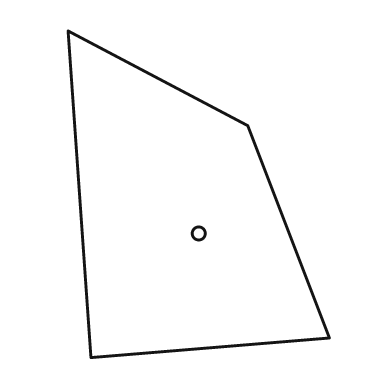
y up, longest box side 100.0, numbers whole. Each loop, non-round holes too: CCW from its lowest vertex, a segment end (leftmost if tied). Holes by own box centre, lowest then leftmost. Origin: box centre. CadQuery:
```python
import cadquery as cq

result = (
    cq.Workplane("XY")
    .moveTo(-33.0, -50.0)
    .lineTo(40.0, -44.0)
    .lineTo(15.0, 21.0)
    .lineTo(-40.0, 50.0)
    .close()
    .moveTo(0.0, -12.0)
    .circle(2.0)
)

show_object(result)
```